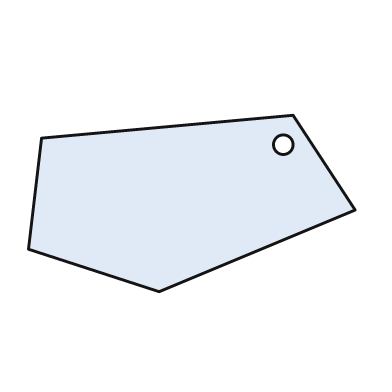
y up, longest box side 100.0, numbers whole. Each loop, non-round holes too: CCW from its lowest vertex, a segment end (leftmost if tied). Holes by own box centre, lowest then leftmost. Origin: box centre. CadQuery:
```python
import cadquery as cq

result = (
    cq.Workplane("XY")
    .moveTo(-10.0, -27.0)
    .lineTo(50.0, -2.0)
    .lineTo(31.0, 27.0)
    .lineTo(-46.0, 20.0)
    .lineTo(-50.0, -14.0)
    .close()
    .moveTo(28.0, 18.0)
    .circle(3.0)
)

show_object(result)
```